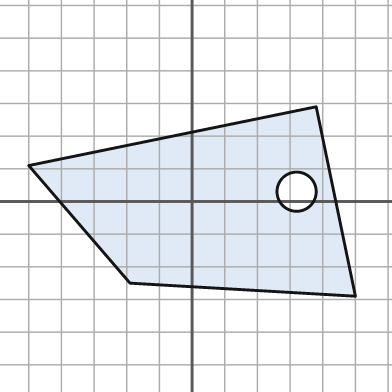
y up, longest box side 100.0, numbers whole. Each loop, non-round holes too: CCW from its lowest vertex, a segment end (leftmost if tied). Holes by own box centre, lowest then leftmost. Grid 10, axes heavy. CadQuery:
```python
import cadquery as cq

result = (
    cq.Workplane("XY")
    .moveTo(50.0, -29.0)
    .lineTo(38.0, 29.0)
    .lineTo(-50.0, 11.0)
    .lineTo(-19.0, -25.0)
    .close()
    .moveTo(32.0, 3.0)
    .circle(6.0)
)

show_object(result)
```